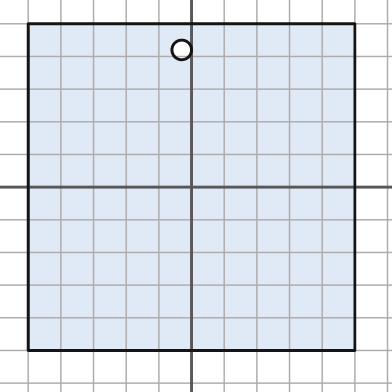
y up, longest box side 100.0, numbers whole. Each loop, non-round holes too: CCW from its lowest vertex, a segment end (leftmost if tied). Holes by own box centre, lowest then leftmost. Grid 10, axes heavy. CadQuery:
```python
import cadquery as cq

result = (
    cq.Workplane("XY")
    .moveTo(-50.0, -50.0)
    .lineTo(50.0, -50.0)
    .lineTo(50.0, 50.0)
    .lineTo(-50.0, 50.0)
    .close()
    .moveTo(-3.0, 42.0)
    .circle(3.0)
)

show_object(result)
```